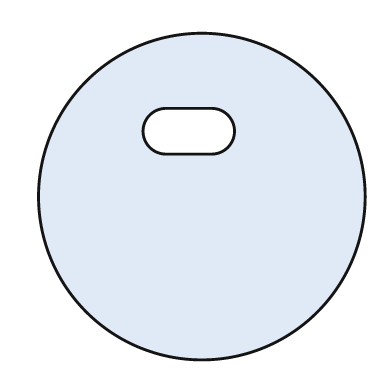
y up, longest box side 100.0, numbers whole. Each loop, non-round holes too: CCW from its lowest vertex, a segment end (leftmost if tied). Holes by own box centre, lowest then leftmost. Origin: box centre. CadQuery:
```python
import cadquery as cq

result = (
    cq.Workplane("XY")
    .moveTo(0.0, 0.0)
    .circle(50.0)
    .moveTo(-11.0, 13.0)
    .lineTo(3.0, 13.0)
    .threePointArc((10.0, 20.0), (3.0, 27.0))
    .lineTo(-11.0, 27.0)
    .threePointArc((-18.0, 20.0), (-11.0, 13.0))
    .close()
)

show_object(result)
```